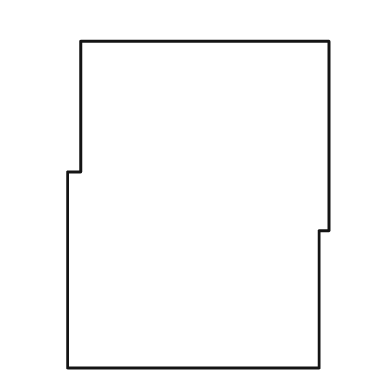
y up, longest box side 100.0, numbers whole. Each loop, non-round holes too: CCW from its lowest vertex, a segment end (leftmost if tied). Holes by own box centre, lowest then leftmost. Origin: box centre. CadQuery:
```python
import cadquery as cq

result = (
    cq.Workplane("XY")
    .moveTo(-40.0, -50.0)
    .lineTo(37.0, -50.0)
    .lineTo(37.0, -8.0)
    .lineTo(40.0, -8.0)
    .lineTo(40.0, 50.0)
    .lineTo(-36.0, 50.0)
    .lineTo(-36.0, 10.0)
    .lineTo(-40.0, 10.0)
    .close()
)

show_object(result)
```